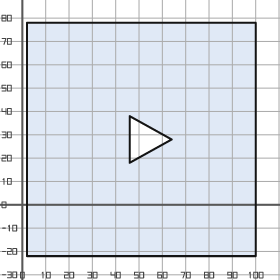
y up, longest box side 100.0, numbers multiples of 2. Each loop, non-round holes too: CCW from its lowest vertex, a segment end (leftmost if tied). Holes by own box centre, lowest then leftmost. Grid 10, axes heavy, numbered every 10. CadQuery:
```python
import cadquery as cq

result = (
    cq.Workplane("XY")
    .moveTo(2.0, -22.0)
    .lineTo(100.0, -22.0)
    .lineTo(100.0, 78.0)
    .lineTo(2.0, 78.0)
    .close()
    .moveTo(46.0, 18.0)
    .lineTo(64.0, 28.0)
    .lineTo(46.0, 38.0)
    .close()
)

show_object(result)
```